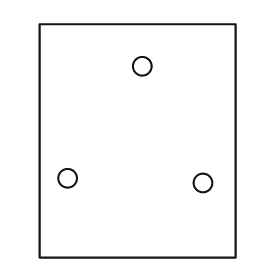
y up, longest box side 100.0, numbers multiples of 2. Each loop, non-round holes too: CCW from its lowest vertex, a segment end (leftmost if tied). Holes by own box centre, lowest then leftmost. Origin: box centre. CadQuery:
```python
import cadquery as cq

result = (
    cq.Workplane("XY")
    .moveTo(-42.0, -50.0)
    .lineTo(42.0, -50.0)
    .lineTo(42.0, 50.0)
    .lineTo(-42.0, 50.0)
    .close()
    .moveTo(28.0, -18.0)
    .circle(4.0)
    .moveTo(-30.0, -16.0)
    .circle(4.0)
    .moveTo(2.0, 32.0)
    .circle(4.0)
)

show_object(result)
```